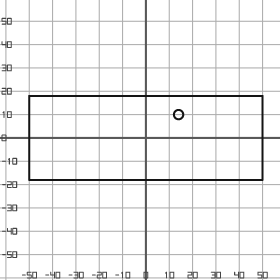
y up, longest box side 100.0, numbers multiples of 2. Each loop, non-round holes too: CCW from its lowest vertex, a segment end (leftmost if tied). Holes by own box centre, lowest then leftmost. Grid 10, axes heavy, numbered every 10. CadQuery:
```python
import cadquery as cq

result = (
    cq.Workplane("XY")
    .moveTo(-50.0, -18.0)
    .lineTo(50.0, -18.0)
    .lineTo(50.0, 18.0)
    .lineTo(-50.0, 18.0)
    .close()
    .moveTo(14.0, 10.0)
    .circle(2.0)
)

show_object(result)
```